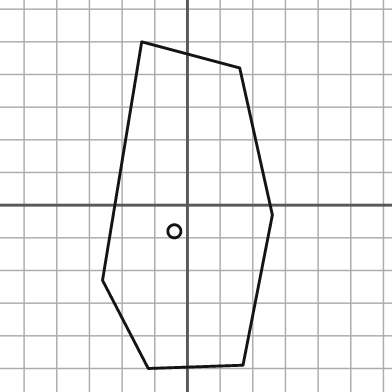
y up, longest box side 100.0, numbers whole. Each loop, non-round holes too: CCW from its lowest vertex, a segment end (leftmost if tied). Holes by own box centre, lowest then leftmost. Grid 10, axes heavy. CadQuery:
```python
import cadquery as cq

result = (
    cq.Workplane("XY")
    .moveTo(-12.0, -50.0)
    .lineTo(17.0, -49.0)
    .lineTo(26.0, -3.0)
    .lineTo(16.0, 42.0)
    .lineTo(-14.0, 50.0)
    .lineTo(-26.0, -23.0)
    .close()
    .moveTo(-4.0, -8.0)
    .circle(2.0)
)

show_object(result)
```